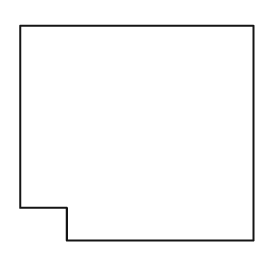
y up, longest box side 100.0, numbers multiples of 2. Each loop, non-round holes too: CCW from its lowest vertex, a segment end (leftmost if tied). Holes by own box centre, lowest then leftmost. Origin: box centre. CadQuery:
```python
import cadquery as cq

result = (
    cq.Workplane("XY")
    .moveTo(-30.0, -46.0)
    .lineTo(50.0, -46.0)
    .lineTo(50.0, 46.0)
    .lineTo(-50.0, 46.0)
    .lineTo(-50.0, -32.0)
    .lineTo(-30.0, -32.0)
    .close()
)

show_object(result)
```